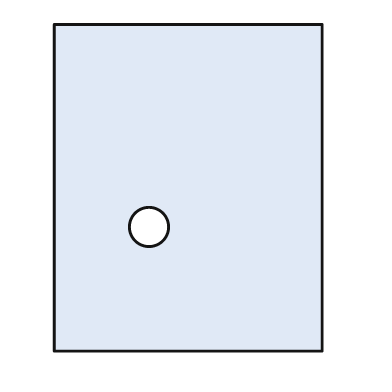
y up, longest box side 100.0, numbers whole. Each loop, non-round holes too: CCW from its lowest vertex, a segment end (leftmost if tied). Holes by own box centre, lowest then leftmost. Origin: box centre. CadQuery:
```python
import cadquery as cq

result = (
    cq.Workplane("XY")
    .moveTo(-41.0, -50.0)
    .lineTo(41.0, -50.0)
    .lineTo(41.0, 50.0)
    .lineTo(-41.0, 50.0)
    .close()
    .moveTo(-12.0, -12.0)
    .circle(6.0)
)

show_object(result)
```